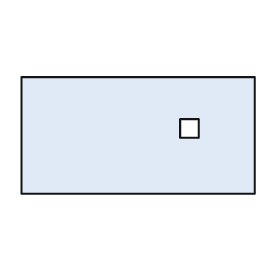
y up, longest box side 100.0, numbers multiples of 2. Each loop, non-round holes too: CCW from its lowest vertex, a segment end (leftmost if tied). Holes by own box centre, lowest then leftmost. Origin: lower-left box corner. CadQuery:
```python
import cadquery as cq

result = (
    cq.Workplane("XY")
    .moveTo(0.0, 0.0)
    .lineTo(100.0, 0.0)
    .lineTo(100.0, 50.0)
    .lineTo(0.0, 50.0)
    .close()
    .moveTo(68.0, 24.0)
    .lineTo(76.0, 24.0)
    .lineTo(76.0, 32.0)
    .lineTo(68.0, 32.0)
    .close()
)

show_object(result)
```